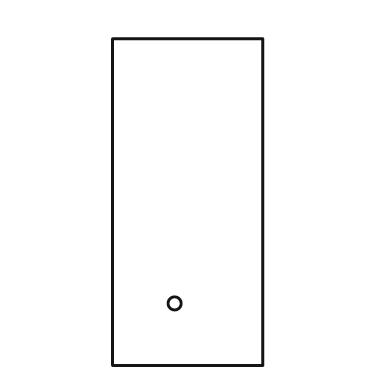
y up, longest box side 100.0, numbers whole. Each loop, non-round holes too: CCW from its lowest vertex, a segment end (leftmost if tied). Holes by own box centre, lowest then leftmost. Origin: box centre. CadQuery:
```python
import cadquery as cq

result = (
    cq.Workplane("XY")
    .moveTo(-23.0, -50.0)
    .lineTo(23.0, -50.0)
    .lineTo(23.0, 50.0)
    .lineTo(-23.0, 50.0)
    .close()
    .moveTo(-4.0, -31.0)
    .circle(2.0)
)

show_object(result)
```